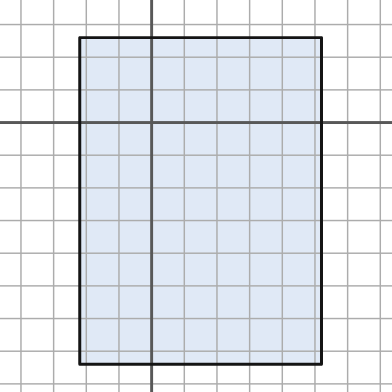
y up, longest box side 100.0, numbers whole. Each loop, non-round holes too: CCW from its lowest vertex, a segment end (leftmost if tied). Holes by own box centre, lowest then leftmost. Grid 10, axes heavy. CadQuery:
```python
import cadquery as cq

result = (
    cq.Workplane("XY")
    .moveTo(-22.0, -74.0)
    .lineTo(52.0, -74.0)
    .lineTo(52.0, 26.0)
    .lineTo(-22.0, 26.0)
    .close()
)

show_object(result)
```